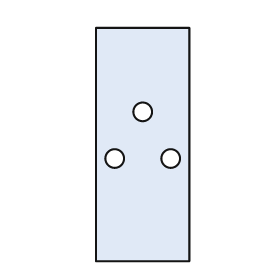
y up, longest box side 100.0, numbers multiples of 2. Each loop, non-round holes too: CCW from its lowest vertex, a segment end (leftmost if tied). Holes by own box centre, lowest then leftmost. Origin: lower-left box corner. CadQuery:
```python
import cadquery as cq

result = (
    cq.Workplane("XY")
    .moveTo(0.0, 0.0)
    .lineTo(40.0, 0.0)
    .lineTo(40.0, 100.0)
    .lineTo(0.0, 100.0)
    .close()
    .moveTo(8.0, 44.0)
    .circle(4.0)
    .moveTo(32.0, 44.0)
    .circle(4.0)
    .moveTo(20.0, 64.0)
    .circle(4.0)
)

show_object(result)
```